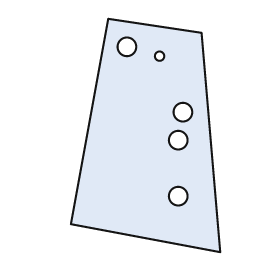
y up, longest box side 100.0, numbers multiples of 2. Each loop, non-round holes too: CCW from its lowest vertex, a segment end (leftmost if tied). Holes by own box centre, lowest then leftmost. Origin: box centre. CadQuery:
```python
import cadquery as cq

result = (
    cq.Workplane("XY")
    .moveTo(32.0, -50.0)
    .lineTo(24.0, 44.0)
    .lineTo(-16.0, 50.0)
    .lineTo(-32.0, -38.0)
    .close()
    .moveTo(14.0, -26.0)
    .circle(4.0)
    .moveTo(14.0, -2.0)
    .circle(4.0)
    .moveTo(16.0, 10.0)
    .circle(4.0)
    .moveTo(6.0, 34.0)
    .circle(2.0)
    .moveTo(-8.0, 38.0)
    .circle(4.0)
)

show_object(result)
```